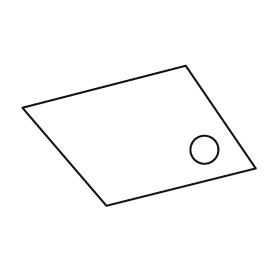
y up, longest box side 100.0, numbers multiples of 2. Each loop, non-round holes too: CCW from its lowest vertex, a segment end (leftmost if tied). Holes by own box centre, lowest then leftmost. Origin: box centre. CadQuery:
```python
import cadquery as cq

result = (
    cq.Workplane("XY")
    .moveTo(-14.0, -30.0)
    .lineTo(50.0, -14.0)
    .lineTo(20.0, 30.0)
    .lineTo(-50.0, 12.0)
    .close()
    .moveTo(28.0, -6.0)
    .circle(6.0)
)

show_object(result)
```